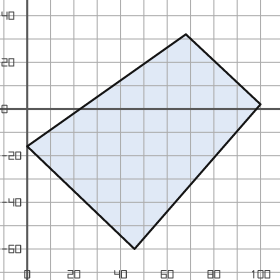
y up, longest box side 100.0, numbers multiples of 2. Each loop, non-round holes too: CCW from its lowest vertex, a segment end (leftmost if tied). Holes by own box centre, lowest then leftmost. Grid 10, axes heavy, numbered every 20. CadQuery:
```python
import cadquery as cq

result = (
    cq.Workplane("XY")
    .moveTo(46.0, -60.0)
    .lineTo(100.0, 2.0)
    .lineTo(68.0, 32.0)
    .lineTo(0.0, -16.0)
    .close()
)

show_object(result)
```